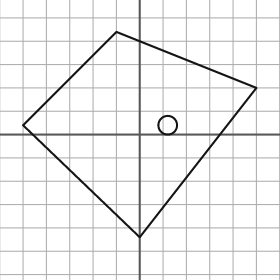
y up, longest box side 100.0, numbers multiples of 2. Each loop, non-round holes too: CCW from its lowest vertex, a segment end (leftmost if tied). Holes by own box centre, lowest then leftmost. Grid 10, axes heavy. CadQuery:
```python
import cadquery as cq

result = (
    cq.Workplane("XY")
    .moveTo(0.0, -44.0)
    .lineTo(50.0, 20.0)
    .lineTo(-10.0, 44.0)
    .lineTo(-50.0, 4.0)
    .close()
    .moveTo(12.0, 4.0)
    .circle(4.0)
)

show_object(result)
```